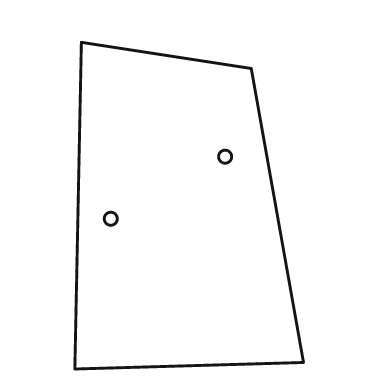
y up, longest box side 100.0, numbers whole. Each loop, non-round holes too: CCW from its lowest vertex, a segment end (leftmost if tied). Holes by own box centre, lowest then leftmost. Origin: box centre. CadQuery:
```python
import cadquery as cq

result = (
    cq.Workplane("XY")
    .moveTo(-35.0, -50.0)
    .lineTo(35.0, -48.0)
    .lineTo(19.0, 42.0)
    .lineTo(-33.0, 50.0)
    .close()
    .moveTo(-24.0, -4.0)
    .circle(2.0)
    .moveTo(11.0, 15.0)
    .circle(2.0)
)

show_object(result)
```